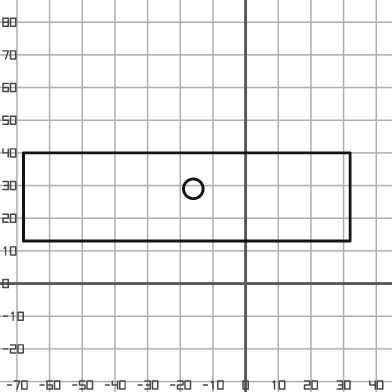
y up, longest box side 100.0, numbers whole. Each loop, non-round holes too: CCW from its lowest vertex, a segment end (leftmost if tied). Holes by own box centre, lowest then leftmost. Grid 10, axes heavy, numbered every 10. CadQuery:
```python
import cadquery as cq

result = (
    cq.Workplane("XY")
    .moveTo(-68.0, 13.0)
    .lineTo(32.0, 13.0)
    .lineTo(32.0, 40.0)
    .lineTo(-68.0, 40.0)
    .close()
    .moveTo(-16.0, 29.0)
    .circle(3.0)
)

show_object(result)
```